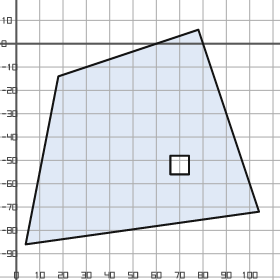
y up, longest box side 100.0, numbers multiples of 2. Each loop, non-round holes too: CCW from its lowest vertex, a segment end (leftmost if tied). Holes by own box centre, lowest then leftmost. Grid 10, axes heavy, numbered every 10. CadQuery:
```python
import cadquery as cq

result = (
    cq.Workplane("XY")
    .moveTo(4.0, -86.0)
    .lineTo(104.0, -72.0)
    .lineTo(78.0, 6.0)
    .lineTo(18.0, -14.0)
    .close()
    .moveTo(66.0, -56.0)
    .lineTo(74.0, -56.0)
    .lineTo(74.0, -48.0)
    .lineTo(66.0, -48.0)
    .close()
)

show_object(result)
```